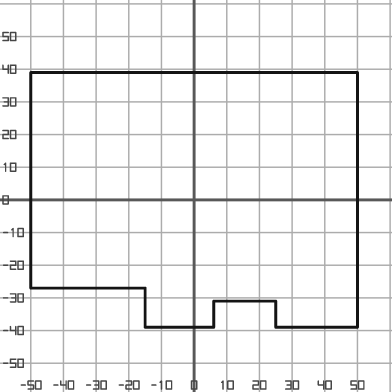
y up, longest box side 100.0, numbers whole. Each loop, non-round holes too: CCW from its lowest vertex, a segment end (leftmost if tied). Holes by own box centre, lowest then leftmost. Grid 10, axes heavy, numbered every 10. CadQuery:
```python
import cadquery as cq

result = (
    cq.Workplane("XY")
    .moveTo(-15.0, -39.0)
    .lineTo(6.0, -39.0)
    .lineTo(6.0, -31.0)
    .lineTo(25.0, -31.0)
    .lineTo(25.0, -39.0)
    .lineTo(50.0, -39.0)
    .lineTo(50.0, 39.0)
    .lineTo(-50.0, 39.0)
    .lineTo(-50.0, -27.0)
    .lineTo(-15.0, -27.0)
    .close()
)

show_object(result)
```